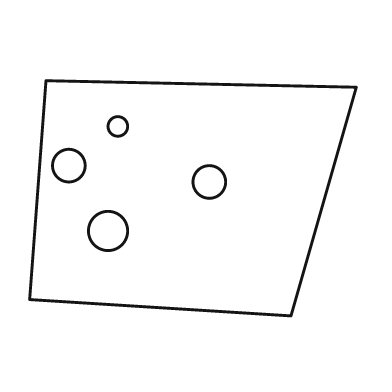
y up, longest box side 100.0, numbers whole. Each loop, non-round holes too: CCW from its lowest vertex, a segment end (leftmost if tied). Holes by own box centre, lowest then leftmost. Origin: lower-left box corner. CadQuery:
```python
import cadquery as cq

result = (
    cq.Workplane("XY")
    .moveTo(80.0, 0.0)
    .lineTo(100.0, 70.0)
    .lineTo(5.0, 72.0)
    .lineTo(0.0, 5.0)
    .close()
    .moveTo(24.0, 26.0)
    .circle(6.0)
    .moveTo(55.0, 41.0)
    .circle(5.0)
    .moveTo(12.0, 46.0)
    .circle(5.0)
    .moveTo(27.0, 58.0)
    .circle(3.0)
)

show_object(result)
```